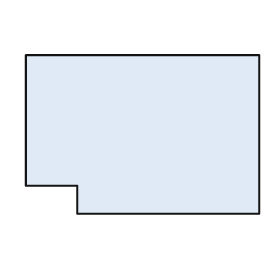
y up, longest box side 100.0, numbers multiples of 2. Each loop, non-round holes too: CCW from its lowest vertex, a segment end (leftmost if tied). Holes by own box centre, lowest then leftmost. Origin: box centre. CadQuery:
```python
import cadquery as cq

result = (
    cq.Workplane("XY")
    .moveTo(-28.0, -34.0)
    .lineTo(50.0, -34.0)
    .lineTo(50.0, 34.0)
    .lineTo(-50.0, 34.0)
    .lineTo(-50.0, -22.0)
    .lineTo(-28.0, -22.0)
    .close()
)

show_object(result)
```